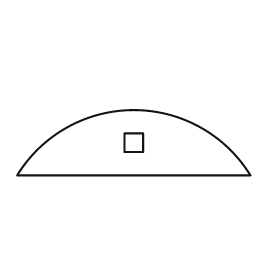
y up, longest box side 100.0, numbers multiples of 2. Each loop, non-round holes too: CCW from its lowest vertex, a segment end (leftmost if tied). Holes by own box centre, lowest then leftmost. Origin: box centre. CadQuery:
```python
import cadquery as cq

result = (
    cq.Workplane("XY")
    .moveTo(-50.0, -14.0)
    .lineTo(50.0, -14.0)
    .threePointArc((0.0, 14.0), (-50.0, -14.0))
    .close()
    .moveTo(-4.0, -4.0)
    .lineTo(4.0, -4.0)
    .lineTo(4.0, 4.0)
    .lineTo(-4.0, 4.0)
    .close()
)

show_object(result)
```